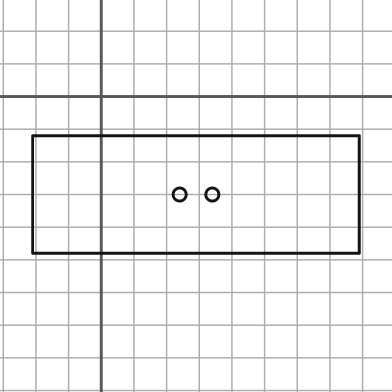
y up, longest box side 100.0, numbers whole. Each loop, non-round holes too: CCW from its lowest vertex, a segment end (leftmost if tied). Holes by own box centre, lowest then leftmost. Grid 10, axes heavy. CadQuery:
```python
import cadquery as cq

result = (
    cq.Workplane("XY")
    .moveTo(-21.0, -48.0)
    .lineTo(79.0, -48.0)
    .lineTo(79.0, -12.0)
    .lineTo(-21.0, -12.0)
    .close()
    .moveTo(24.0, -30.0)
    .circle(2.0)
    .moveTo(34.0, -30.0)
    .circle(2.0)
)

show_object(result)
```